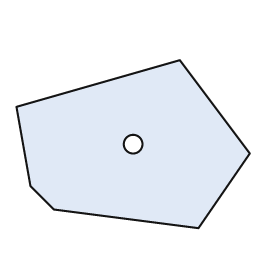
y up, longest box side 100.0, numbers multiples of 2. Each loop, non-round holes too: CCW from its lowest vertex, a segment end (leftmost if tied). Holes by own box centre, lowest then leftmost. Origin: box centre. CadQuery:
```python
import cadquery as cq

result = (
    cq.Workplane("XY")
    .moveTo(28.0, -36.0)
    .lineTo(50.0, -4.0)
    .lineTo(20.0, 36.0)
    .lineTo(-50.0, 16.0)
    .lineTo(-44.0, -18.0)
    .lineTo(-34.0, -28.0)
    .close()
    .moveTo(0.0, 0.0)
    .circle(4.0)
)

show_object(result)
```